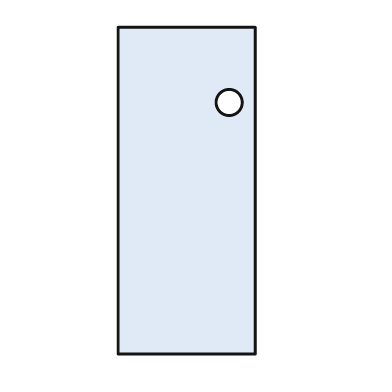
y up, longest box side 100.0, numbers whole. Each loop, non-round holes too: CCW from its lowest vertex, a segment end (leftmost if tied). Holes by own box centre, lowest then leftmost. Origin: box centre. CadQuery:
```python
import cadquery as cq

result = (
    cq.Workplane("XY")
    .moveTo(-21.0, -50.0)
    .lineTo(21.0, -50.0)
    .lineTo(21.0, 50.0)
    .lineTo(-21.0, 50.0)
    .close()
    .moveTo(13.0, 27.0)
    .circle(4.0)
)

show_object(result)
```